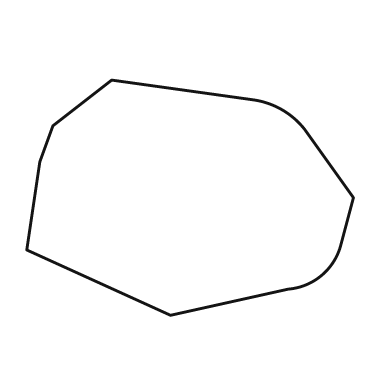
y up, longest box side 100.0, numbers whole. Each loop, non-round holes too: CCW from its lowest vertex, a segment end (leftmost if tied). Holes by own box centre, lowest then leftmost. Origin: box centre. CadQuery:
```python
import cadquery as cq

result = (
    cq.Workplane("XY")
    .moveTo(-6.0, -36.0)
    .lineTo(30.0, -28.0)
    .threePointArc((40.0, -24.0), (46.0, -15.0))
    .lineTo(50.0, 0.0)
    .lineTo(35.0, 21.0)
    .threePointArc((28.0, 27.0), (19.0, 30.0))
    .lineTo(-24.0, 36.0)
    .lineTo(-42.0, 22.0)
    .lineTo(-46.0, 11.0)
    .lineTo(-50.0, -16.0)
    .close()
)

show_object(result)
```